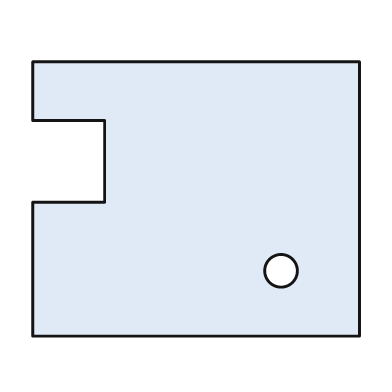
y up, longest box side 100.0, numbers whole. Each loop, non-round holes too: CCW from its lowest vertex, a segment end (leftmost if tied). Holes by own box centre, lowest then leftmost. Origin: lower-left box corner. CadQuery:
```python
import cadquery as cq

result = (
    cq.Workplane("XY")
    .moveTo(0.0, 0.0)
    .lineTo(100.0, 0.0)
    .lineTo(100.0, 84.0)
    .lineTo(0.0, 84.0)
    .lineTo(0.0, 66.0)
    .lineTo(22.0, 66.0)
    .lineTo(22.0, 41.0)
    .lineTo(0.0, 41.0)
    .close()
    .moveTo(76.0, 20.0)
    .circle(5.0)
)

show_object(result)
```